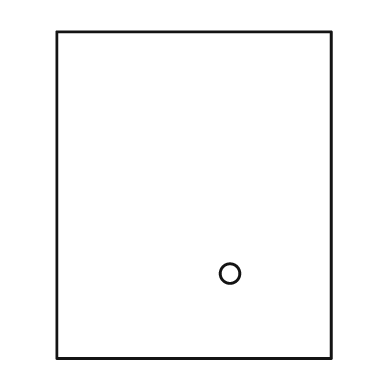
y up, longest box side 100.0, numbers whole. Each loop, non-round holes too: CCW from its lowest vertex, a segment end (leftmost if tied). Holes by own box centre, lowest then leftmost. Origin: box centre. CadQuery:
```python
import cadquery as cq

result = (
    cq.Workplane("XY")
    .moveTo(-42.0, -50.0)
    .lineTo(42.0, -50.0)
    .lineTo(42.0, 50.0)
    .lineTo(-42.0, 50.0)
    .close()
    .moveTo(11.0, -24.0)
    .circle(3.0)
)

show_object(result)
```